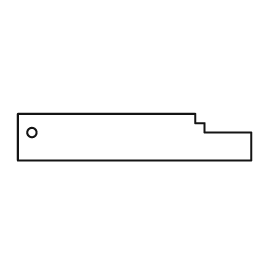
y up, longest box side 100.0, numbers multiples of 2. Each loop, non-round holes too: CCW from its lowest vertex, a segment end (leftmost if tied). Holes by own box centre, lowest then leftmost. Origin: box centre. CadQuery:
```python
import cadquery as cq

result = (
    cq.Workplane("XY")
    .moveTo(-50.0, -10.0)
    .lineTo(50.0, -10.0)
    .lineTo(50.0, 2.0)
    .lineTo(30.0, 2.0)
    .lineTo(30.0, 6.0)
    .lineTo(26.0, 6.0)
    .lineTo(26.0, 10.0)
    .lineTo(-50.0, 10.0)
    .close()
    .moveTo(-44.0, 2.0)
    .circle(2.0)
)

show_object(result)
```